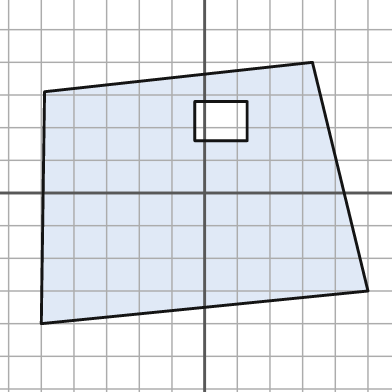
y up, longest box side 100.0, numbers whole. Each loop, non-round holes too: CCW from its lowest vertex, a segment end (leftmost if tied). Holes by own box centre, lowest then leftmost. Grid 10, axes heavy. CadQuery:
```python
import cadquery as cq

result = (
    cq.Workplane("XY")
    .moveTo(-50.0, -40.0)
    .lineTo(50.0, -30.0)
    .lineTo(33.0, 40.0)
    .lineTo(-49.0, 31.0)
    .close()
    .moveTo(-3.0, 16.0)
    .lineTo(13.0, 16.0)
    .lineTo(13.0, 28.0)
    .lineTo(-3.0, 28.0)
    .close()
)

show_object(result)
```